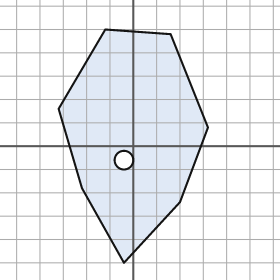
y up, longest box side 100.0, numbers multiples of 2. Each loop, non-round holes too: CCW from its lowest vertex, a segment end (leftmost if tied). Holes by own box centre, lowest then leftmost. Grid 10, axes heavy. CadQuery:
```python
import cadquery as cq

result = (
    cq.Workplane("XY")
    .moveTo(-4.0, -50.0)
    .lineTo(20.0, -24.0)
    .lineTo(32.0, 8.0)
    .lineTo(16.0, 48.0)
    .lineTo(-12.0, 50.0)
    .lineTo(-32.0, 16.0)
    .lineTo(-22.0, -18.0)
    .close()
    .moveTo(-4.0, -6.0)
    .circle(4.0)
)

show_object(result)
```